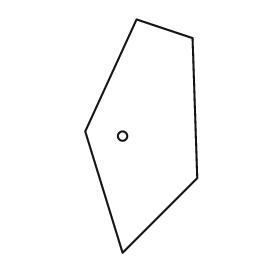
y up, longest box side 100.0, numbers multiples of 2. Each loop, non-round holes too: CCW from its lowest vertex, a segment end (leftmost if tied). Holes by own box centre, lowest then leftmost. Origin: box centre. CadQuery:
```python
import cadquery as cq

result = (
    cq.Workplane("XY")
    .moveTo(-8.0, -50.0)
    .lineTo(24.0, -18.0)
    .lineTo(22.0, 42.0)
    .lineTo(-2.0, 50.0)
    .lineTo(-24.0, 2.0)
    .close()
    .moveTo(-8.0, 0.0)
    .circle(2.0)
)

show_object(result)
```